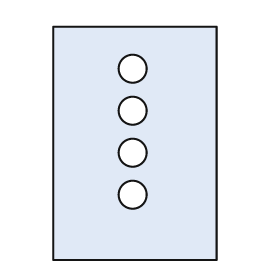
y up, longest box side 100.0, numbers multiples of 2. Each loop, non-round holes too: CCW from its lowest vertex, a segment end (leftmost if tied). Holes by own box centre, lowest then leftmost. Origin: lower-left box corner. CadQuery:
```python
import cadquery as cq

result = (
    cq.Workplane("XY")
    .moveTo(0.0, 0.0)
    .lineTo(70.0, 0.0)
    .lineTo(70.0, 100.0)
    .lineTo(0.0, 100.0)
    .close()
    .moveTo(34.0, 28.0)
    .circle(6.0)
    .moveTo(34.0, 46.0)
    .circle(6.0)
    .moveTo(34.0, 64.0)
    .circle(6.0)
    .moveTo(34.0, 82.0)
    .circle(6.0)
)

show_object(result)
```